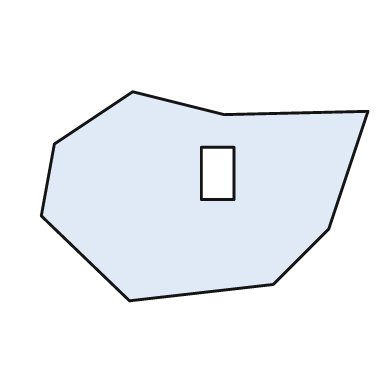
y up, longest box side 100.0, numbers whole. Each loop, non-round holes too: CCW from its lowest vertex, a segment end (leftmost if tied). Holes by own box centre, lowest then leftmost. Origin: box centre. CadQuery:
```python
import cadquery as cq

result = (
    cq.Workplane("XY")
    .moveTo(-23.0, -32.0)
    .lineTo(21.0, -27.0)
    .lineTo(38.0, -10.0)
    .lineTo(50.0, 26.0)
    .lineTo(6.0, 25.0)
    .lineTo(-22.0, 32.0)
    .lineTo(-46.0, 16.0)
    .lineTo(-50.0, -6.0)
    .close()
    .moveTo(-1.0, -1.0)
    .lineTo(9.0, -1.0)
    .lineTo(9.0, 15.0)
    .lineTo(-1.0, 15.0)
    .close()
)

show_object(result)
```